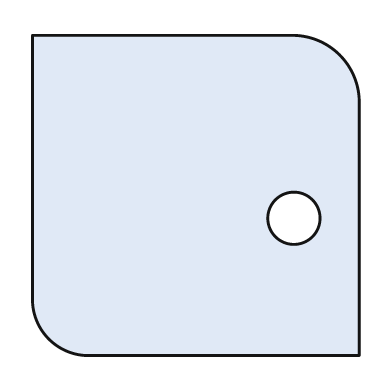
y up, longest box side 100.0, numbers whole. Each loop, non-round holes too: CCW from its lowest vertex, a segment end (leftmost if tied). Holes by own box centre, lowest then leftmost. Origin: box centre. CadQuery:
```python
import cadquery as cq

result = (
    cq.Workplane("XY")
    .moveTo(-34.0, -49.0)
    .lineTo(50.0, -49.0)
    .lineTo(50.0, 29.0)
    .threePointArc((44.0, 43.0), (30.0, 49.0))
    .lineTo(-50.0, 49.0)
    .lineTo(-50.0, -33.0)
    .threePointArc((-45.0, -44.0), (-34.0, -49.0))
    .close()
    .moveTo(30.0, -7.0)
    .circle(8.0)
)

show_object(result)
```